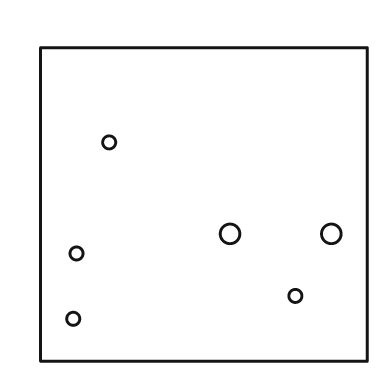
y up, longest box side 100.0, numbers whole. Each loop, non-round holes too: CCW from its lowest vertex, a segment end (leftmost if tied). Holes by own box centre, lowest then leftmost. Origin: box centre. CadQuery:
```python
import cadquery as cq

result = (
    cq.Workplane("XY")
    .moveTo(-50.0, -48.0)
    .lineTo(50.0, -48.0)
    .lineTo(50.0, 48.0)
    .lineTo(-50.0, 48.0)
    .close()
    .moveTo(-40.0, -35.0)
    .circle(2.0)
    .moveTo(28.0, -28.0)
    .circle(2.0)
    .moveTo(-39.0, -15.0)
    .circle(2.0)
    .moveTo(8.0, -9.0)
    .circle(3.0)
    .moveTo(39.0, -9.0)
    .circle(3.0)
    .moveTo(-29.0, 19.0)
    .circle(2.0)
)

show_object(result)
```